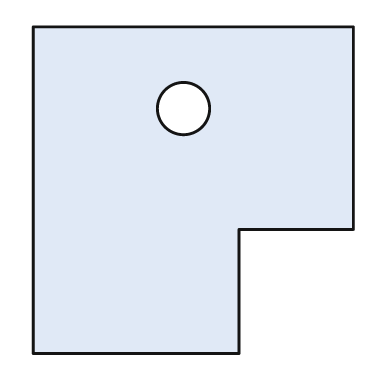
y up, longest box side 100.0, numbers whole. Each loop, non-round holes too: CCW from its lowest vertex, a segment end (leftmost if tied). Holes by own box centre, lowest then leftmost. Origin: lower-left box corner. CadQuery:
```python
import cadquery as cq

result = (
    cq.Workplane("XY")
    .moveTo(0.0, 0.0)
    .lineTo(63.0, 0.0)
    .lineTo(63.0, 38.0)
    .lineTo(98.0, 38.0)
    .lineTo(98.0, 100.0)
    .lineTo(0.0, 100.0)
    .close()
    .moveTo(46.0, 75.0)
    .circle(8.0)
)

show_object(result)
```